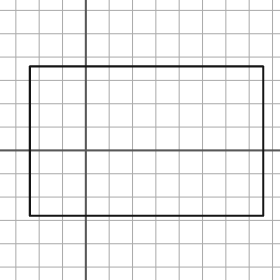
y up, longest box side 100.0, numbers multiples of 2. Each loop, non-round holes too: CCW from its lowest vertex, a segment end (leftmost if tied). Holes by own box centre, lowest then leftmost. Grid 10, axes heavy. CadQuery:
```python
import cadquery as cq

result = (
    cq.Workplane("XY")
    .moveTo(-24.0, -28.0)
    .lineTo(76.0, -28.0)
    .lineTo(76.0, 36.0)
    .lineTo(-24.0, 36.0)
    .close()
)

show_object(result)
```